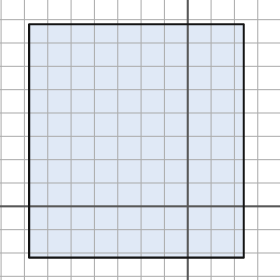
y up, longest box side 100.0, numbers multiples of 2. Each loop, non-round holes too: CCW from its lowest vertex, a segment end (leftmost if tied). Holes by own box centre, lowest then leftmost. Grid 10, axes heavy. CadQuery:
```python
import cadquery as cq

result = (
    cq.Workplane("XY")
    .moveTo(-68.0, -22.0)
    .lineTo(24.0, -22.0)
    .lineTo(24.0, 78.0)
    .lineTo(-68.0, 78.0)
    .close()
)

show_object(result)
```